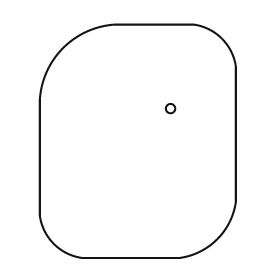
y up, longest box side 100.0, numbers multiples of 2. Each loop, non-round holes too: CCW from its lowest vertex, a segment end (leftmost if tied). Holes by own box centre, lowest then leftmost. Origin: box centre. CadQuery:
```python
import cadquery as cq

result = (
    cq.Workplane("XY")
    .moveTo(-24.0, -50.0)
    .lineTo(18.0, -50.0)
    .threePointArc((34.0, -42.0), (42.0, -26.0))
    .lineTo(42.0, 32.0)
    .threePointArc((36.0, 44.0), (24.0, 50.0))
    .lineTo(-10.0, 50.0)
    .threePointArc((-32.0, 40.0), (-42.0, 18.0))
    .lineTo(-42.0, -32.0)
    .threePointArc((-36.0, -44.0), (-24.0, -50.0))
    .close()
    .moveTo(14.0, 14.0)
    .circle(2.0)
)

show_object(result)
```